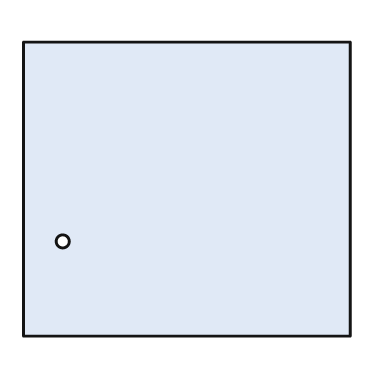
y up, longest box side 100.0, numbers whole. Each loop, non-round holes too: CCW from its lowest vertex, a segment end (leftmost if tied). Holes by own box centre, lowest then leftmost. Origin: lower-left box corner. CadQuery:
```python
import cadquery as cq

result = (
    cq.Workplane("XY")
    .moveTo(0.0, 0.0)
    .lineTo(100.0, 0.0)
    .lineTo(100.0, 90.0)
    .lineTo(0.0, 90.0)
    .close()
    .moveTo(12.0, 29.0)
    .circle(2.0)
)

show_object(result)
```